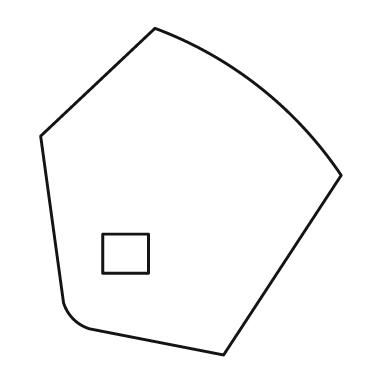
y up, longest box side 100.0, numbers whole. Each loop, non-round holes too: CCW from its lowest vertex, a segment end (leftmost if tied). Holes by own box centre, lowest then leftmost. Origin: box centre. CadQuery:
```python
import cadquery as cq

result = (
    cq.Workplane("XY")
    .moveTo(10.0, -50.0)
    .lineTo(46.0, 5.0)
    .threePointArc((21.0, 32.0), (-11.0, 50.0))
    .lineTo(-46.0, 17.0)
    .lineTo(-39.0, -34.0)
    .threePointArc((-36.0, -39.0), (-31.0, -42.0))
    .close()
    .moveTo(-27.0, -25.0)
    .lineTo(-13.0, -25.0)
    .lineTo(-13.0, -13.0)
    .lineTo(-27.0, -13.0)
    .close()
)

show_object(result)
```